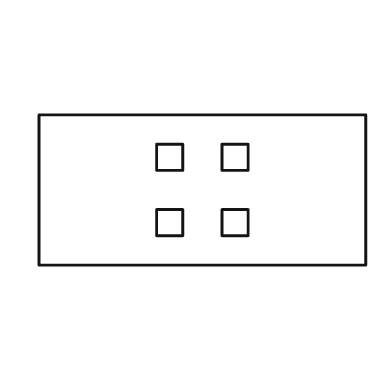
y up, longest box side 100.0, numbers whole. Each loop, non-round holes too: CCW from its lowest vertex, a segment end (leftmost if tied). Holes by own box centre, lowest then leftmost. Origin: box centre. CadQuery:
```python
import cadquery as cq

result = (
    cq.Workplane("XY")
    .moveTo(-50.0, -23.0)
    .lineTo(50.0, -23.0)
    .lineTo(50.0, 23.0)
    .lineTo(-50.0, 23.0)
    .close()
    .moveTo(-14.0, -14.0)
    .lineTo(-6.0, -14.0)
    .lineTo(-6.0, -6.0)
    .lineTo(-14.0, -6.0)
    .close()
    .moveTo(6.0, -14.0)
    .lineTo(14.0, -14.0)
    .lineTo(14.0, -6.0)
    .lineTo(6.0, -6.0)
    .close()
    .moveTo(-14.0, 6.0)
    .lineTo(-6.0, 6.0)
    .lineTo(-6.0, 14.0)
    .lineTo(-14.0, 14.0)
    .close()
    .moveTo(6.0, 6.0)
    .lineTo(14.0, 6.0)
    .lineTo(14.0, 14.0)
    .lineTo(6.0, 14.0)
    .close()
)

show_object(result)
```